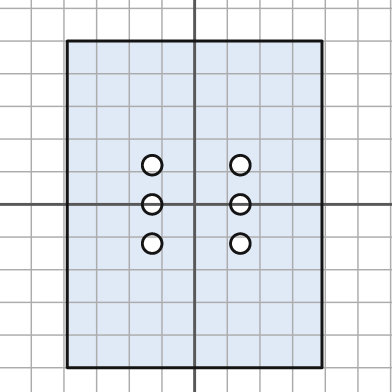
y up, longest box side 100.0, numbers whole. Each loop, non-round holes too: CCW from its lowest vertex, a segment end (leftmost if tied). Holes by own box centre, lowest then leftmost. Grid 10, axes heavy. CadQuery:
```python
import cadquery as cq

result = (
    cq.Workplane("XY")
    .moveTo(-39.0, -50.0)
    .lineTo(39.0, -50.0)
    .lineTo(39.0, 50.0)
    .lineTo(-39.0, 50.0)
    .close()
    .moveTo(-13.0, -12.0)
    .circle(3.0)
    .moveTo(14.0, -12.0)
    .circle(3.0)
    .moveTo(-13.0, 0.0)
    .circle(3.0)
    .moveTo(14.0, 0.0)
    .circle(3.0)
    .moveTo(-13.0, 12.0)
    .circle(3.0)
    .moveTo(14.0, 12.0)
    .circle(3.0)
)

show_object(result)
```